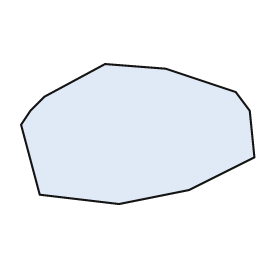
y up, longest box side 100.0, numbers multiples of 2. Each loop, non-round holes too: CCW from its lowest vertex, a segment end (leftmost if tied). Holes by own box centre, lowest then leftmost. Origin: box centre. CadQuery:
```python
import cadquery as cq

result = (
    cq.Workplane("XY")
    .moveTo(-8.0, -30.0)
    .lineTo(22.0, -24.0)
    .lineTo(50.0, -10.0)
    .lineTo(48.0, 10.0)
    .lineTo(42.0, 18.0)
    .lineTo(12.0, 28.0)
    .lineTo(-14.0, 30.0)
    .lineTo(-40.0, 16.0)
    .lineTo(-46.0, 10.0)
    .lineTo(-50.0, 4.0)
    .lineTo(-42.0, -26.0)
    .close()
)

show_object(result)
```